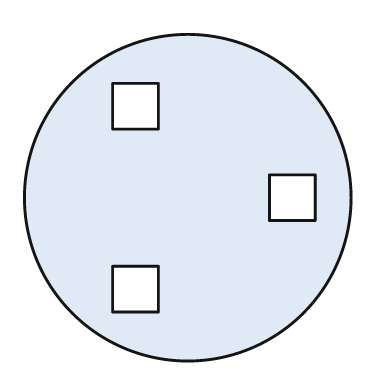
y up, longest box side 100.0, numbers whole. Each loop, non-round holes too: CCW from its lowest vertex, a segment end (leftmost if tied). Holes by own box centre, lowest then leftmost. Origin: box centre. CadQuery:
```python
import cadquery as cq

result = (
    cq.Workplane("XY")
    .moveTo(0.0, 0.0)
    .circle(50.0)
    .moveTo(-23.0, -35.0)
    .lineTo(-9.0, -35.0)
    .lineTo(-9.0, -21.0)
    .lineTo(-23.0, -21.0)
    .close()
    .moveTo(25.0, -7.0)
    .lineTo(39.0, -7.0)
    .lineTo(39.0, 7.0)
    .lineTo(25.0, 7.0)
    .close()
    .moveTo(-23.0, 21.0)
    .lineTo(-9.0, 21.0)
    .lineTo(-9.0, 35.0)
    .lineTo(-23.0, 35.0)
    .close()
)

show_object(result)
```